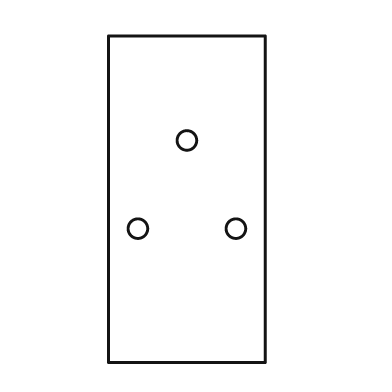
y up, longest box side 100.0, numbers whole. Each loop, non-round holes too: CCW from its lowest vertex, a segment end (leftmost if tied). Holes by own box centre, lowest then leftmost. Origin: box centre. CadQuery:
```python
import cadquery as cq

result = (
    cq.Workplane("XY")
    .moveTo(-24.0, -50.0)
    .lineTo(24.0, -50.0)
    .lineTo(24.0, 50.0)
    .lineTo(-24.0, 50.0)
    .close()
    .moveTo(-15.0, -9.0)
    .circle(3.0)
    .moveTo(15.0, -9.0)
    .circle(3.0)
    .moveTo(0.0, 18.0)
    .circle(3.0)
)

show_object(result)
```